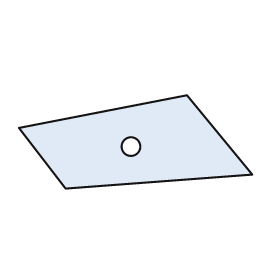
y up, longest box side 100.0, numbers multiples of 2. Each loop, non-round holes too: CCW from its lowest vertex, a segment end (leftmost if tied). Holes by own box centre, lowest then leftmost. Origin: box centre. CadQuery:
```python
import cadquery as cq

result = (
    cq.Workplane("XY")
    .moveTo(-30.0, -20.0)
    .lineTo(50.0, -14.0)
    .lineTo(22.0, 20.0)
    .lineTo(-50.0, 6.0)
    .close()
    .moveTo(-2.0, -2.0)
    .circle(4.0)
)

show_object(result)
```